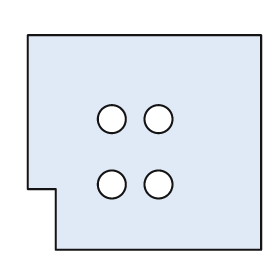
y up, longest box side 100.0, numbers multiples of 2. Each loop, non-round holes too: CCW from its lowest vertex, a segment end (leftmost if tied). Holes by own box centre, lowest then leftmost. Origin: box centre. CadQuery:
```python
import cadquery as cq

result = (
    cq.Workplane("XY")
    .moveTo(-38.0, -46.0)
    .lineTo(50.0, -46.0)
    .lineTo(50.0, 46.0)
    .lineTo(-50.0, 46.0)
    .lineTo(-50.0, -20.0)
    .lineTo(-38.0, -20.0)
    .close()
    .moveTo(-14.0, -18.0)
    .circle(6.0)
    .moveTo(6.0, -18.0)
    .circle(6.0)
    .moveTo(-14.0, 10.0)
    .circle(6.0)
    .moveTo(6.0, 10.0)
    .circle(6.0)
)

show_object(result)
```